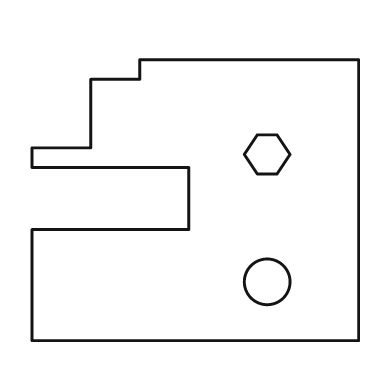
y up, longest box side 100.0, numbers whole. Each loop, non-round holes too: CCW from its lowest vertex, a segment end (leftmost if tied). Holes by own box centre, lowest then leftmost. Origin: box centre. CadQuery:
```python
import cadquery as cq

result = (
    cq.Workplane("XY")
    .moveTo(-50.0, -43.0)
    .lineTo(50.0, -43.0)
    .lineTo(50.0, 43.0)
    .lineTo(-17.0, 43.0)
    .lineTo(-17.0, 37.0)
    .lineTo(-32.0, 37.0)
    .lineTo(-32.0, 16.0)
    .lineTo(-50.0, 16.0)
    .lineTo(-50.0, 10.0)
    .lineTo(-2.0, 10.0)
    .lineTo(-2.0, -9.0)
    .lineTo(-50.0, -9.0)
    .close()
    .moveTo(22.0, -25.0)
    .circle(7.0)
    .moveTo(19.0, 8.0)
    .lineTo(25.0, 8.0)
    .lineTo(29.0, 14.0)
    .lineTo(25.0, 20.0)
    .lineTo(19.0, 20.0)
    .lineTo(15.0, 14.0)
    .close()
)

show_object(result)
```